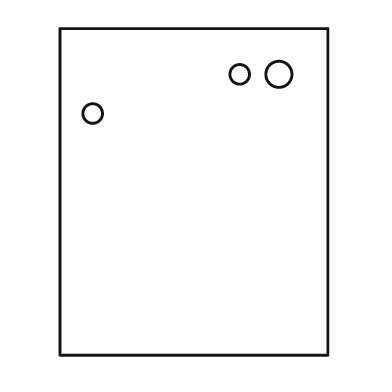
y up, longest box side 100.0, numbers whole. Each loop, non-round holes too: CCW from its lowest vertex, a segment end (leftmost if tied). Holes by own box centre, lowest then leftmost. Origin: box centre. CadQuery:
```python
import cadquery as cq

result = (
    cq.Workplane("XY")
    .moveTo(-41.0, -50.0)
    .lineTo(41.0, -50.0)
    .lineTo(41.0, 50.0)
    .lineTo(-41.0, 50.0)
    .close()
    .moveTo(-31.0, 24.0)
    .circle(3.0)
    .moveTo(14.0, 36.0)
    .circle(3.0)
    .moveTo(26.0, 36.0)
    .circle(4.0)
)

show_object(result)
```